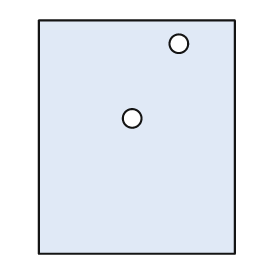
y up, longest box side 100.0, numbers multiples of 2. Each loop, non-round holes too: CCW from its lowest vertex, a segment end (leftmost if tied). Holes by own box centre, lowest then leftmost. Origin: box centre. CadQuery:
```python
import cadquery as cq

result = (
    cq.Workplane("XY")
    .moveTo(-42.0, -50.0)
    .lineTo(42.0, -50.0)
    .lineTo(42.0, 50.0)
    .lineTo(-42.0, 50.0)
    .close()
    .moveTo(-2.0, 8.0)
    .circle(4.0)
    .moveTo(18.0, 40.0)
    .circle(4.0)
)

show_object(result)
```